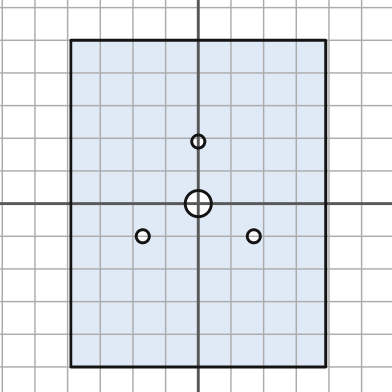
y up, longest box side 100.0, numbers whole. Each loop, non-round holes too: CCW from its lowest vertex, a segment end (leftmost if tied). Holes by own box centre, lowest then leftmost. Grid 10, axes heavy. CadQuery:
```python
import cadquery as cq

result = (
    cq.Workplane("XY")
    .moveTo(-39.0, -50.0)
    .lineTo(39.0, -50.0)
    .lineTo(39.0, 50.0)
    .lineTo(-39.0, 50.0)
    .close()
    .moveTo(-17.0, -10.0)
    .circle(2.0)
    .moveTo(17.0, -10.0)
    .circle(2.0)
    .moveTo(0.0, 0.0)
    .circle(4.0)
    .moveTo(0.0, 19.0)
    .circle(2.0)
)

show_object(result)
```